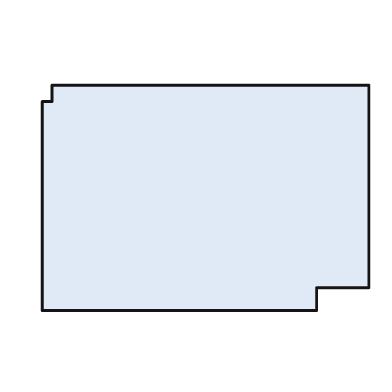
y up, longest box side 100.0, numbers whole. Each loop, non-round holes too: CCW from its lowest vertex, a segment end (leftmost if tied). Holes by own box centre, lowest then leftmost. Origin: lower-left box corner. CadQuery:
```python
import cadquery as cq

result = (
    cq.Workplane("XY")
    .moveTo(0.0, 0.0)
    .lineTo(84.0, 0.0)
    .lineTo(84.0, 7.0)
    .lineTo(100.0, 7.0)
    .lineTo(100.0, 69.0)
    .lineTo(3.0, 69.0)
    .lineTo(3.0, 64.0)
    .lineTo(0.0, 64.0)
    .close()
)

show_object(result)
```